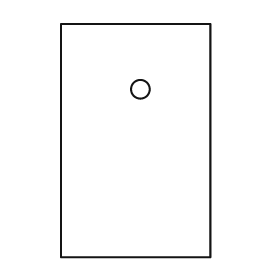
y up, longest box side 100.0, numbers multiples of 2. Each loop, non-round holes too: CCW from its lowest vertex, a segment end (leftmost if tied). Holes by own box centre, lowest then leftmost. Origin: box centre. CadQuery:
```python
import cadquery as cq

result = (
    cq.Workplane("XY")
    .moveTo(-32.0, -50.0)
    .lineTo(32.0, -50.0)
    .lineTo(32.0, 50.0)
    .lineTo(-32.0, 50.0)
    .close()
    .moveTo(2.0, 22.0)
    .circle(4.0)
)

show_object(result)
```